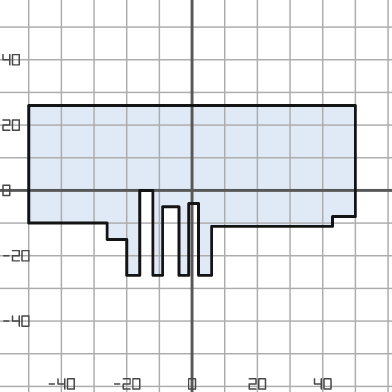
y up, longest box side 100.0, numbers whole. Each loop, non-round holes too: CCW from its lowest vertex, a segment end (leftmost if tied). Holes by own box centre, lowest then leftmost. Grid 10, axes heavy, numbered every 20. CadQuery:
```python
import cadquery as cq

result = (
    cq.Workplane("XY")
    .moveTo(-20.0, -26.0)
    .lineTo(-16.0, -26.0)
    .lineTo(-16.0, 0.0)
    .lineTo(-12.0, 0.0)
    .lineTo(-12.0, -26.0)
    .lineTo(-9.0, -26.0)
    .lineTo(-9.0, -5.0)
    .lineTo(-4.0, -5.0)
    .lineTo(-4.0, -26.0)
    .lineTo(-1.0, -26.0)
    .lineTo(-1.0, -4.0)
    .lineTo(2.0, -4.0)
    .lineTo(2.0, -26.0)
    .lineTo(6.0, -26.0)
    .lineTo(6.0, -11.0)
    .lineTo(43.0, -11.0)
    .lineTo(43.0, -8.0)
    .lineTo(50.0, -8.0)
    .lineTo(50.0, 26.0)
    .lineTo(-50.0, 26.0)
    .lineTo(-50.0, -10.0)
    .lineTo(-26.0, -10.0)
    .lineTo(-26.0, -15.0)
    .lineTo(-20.0, -15.0)
    .close()
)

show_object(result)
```